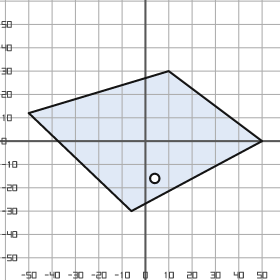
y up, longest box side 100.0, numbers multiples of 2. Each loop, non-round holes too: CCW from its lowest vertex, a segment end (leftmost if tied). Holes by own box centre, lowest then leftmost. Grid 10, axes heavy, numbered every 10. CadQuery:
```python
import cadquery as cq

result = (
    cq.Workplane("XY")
    .moveTo(-6.0, -30.0)
    .lineTo(50.0, 0.0)
    .lineTo(10.0, 30.0)
    .lineTo(-50.0, 12.0)
    .close()
    .moveTo(4.0, -16.0)
    .circle(2.0)
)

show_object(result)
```